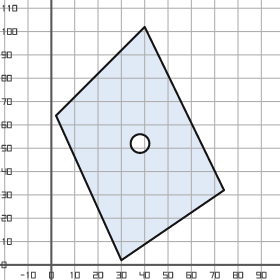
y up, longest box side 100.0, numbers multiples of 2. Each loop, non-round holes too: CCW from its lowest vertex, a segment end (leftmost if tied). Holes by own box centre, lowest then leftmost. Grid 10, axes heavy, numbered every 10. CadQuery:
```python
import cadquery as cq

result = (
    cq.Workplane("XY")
    .moveTo(30.0, 2.0)
    .lineTo(74.0, 32.0)
    .lineTo(40.0, 102.0)
    .lineTo(2.0, 64.0)
    .close()
    .moveTo(38.0, 52.0)
    .circle(4.0)
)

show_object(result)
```